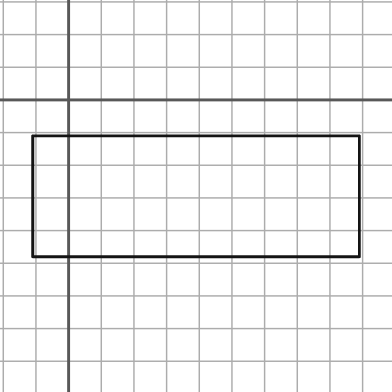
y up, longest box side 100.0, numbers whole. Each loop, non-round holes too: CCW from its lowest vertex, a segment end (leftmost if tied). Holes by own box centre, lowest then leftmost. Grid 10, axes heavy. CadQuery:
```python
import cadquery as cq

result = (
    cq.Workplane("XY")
    .moveTo(-11.0, -48.0)
    .lineTo(89.0, -48.0)
    .lineTo(89.0, -11.0)
    .lineTo(-11.0, -11.0)
    .close()
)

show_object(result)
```